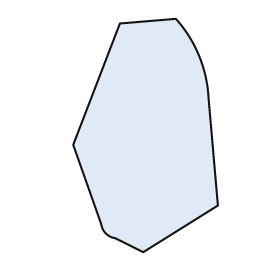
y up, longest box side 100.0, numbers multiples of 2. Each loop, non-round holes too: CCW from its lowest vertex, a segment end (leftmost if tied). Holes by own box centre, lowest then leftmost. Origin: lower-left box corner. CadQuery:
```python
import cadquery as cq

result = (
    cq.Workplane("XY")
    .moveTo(30.0, 0.0)
    .lineTo(62.0, 20.0)
    .lineTo(58.0, 66.0)
    .threePointArc((54.0, 84.0), (44.0, 100.0))
    .lineTo(20.0, 98.0)
    .lineTo(0.0, 46.0)
    .lineTo(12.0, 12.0)
    .threePointArc((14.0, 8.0), (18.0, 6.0))
    .close()
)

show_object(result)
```